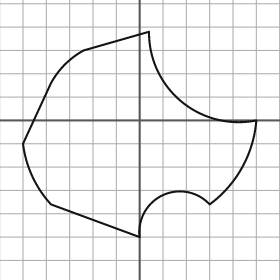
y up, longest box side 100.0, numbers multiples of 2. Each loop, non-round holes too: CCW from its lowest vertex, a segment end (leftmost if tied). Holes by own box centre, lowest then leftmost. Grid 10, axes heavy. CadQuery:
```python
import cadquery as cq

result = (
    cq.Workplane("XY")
    .moveTo(0.0, -50.0)
    .threePointArc((10.0, -32.0), (30.0, -36.0))
    .threePointArc((44.0, -20.0), (50.0, 0.0))
    .threePointArc((18.0, 8.0), (4.0, 38.0))
    .lineTo(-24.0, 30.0)
    .threePointArc((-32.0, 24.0), (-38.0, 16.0))
    .lineTo(-50.0, -10.0)
    .threePointArc((-46.0, -24.0), (-38.0, -36.0))
    .close()
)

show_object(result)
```